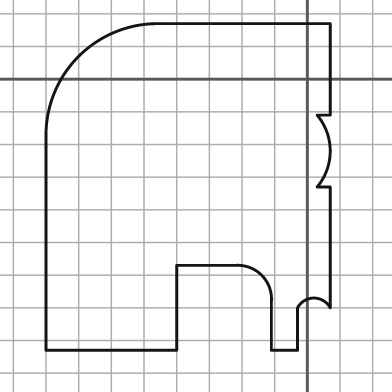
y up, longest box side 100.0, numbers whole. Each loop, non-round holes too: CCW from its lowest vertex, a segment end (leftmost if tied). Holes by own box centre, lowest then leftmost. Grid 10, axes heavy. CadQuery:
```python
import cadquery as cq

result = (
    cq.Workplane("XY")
    .moveTo(-80.0, -83.0)
    .lineTo(-40.0, -83.0)
    .lineTo(-40.0, -57.0)
    .lineTo(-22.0, -57.0)
    .threePointArc((-14.0, -60.0), (-11.0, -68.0))
    .lineTo(-11.0, -83.0)
    .lineTo(-3.0, -83.0)
    .lineTo(-3.0, -70.0)
    .threePointArc((2.0, -67.0), (7.0, -70.0))
    .lineTo(7.0, -33.0)
    .lineTo(3.0, -33.0)
    .threePointArc((7.0, -22.0), (3.0, -11.0))
    .lineTo(7.0, -11.0)
    .lineTo(7.0, 17.0)
    .lineTo(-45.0, 17.0)
    .threePointArc((-70.0, 7.0), (-80.0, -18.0))
    .close()
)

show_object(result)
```